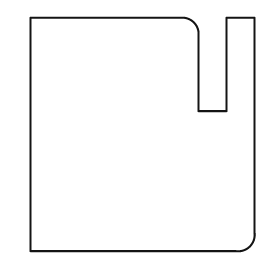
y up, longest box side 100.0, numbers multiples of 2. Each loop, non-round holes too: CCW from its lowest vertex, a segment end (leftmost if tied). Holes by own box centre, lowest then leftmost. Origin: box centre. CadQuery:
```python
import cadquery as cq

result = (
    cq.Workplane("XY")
    .moveTo(-48.0, -50.0)
    .lineTo(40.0, -50.0)
    .threePointArc((46.0, -48.0), (48.0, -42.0))
    .lineTo(48.0, 50.0)
    .lineTo(36.0, 50.0)
    .lineTo(36.0, 10.0)
    .lineTo(24.0, 10.0)
    .lineTo(24.0, 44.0)
    .threePointArc((22.0, 48.0), (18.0, 50.0))
    .lineTo(-48.0, 50.0)
    .close()
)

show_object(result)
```